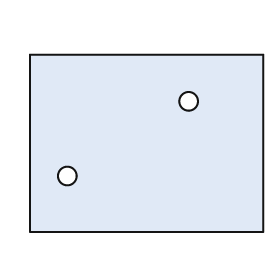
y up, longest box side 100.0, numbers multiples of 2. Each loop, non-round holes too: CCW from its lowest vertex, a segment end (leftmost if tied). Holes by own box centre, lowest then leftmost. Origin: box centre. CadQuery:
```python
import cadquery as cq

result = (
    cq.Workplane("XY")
    .moveTo(-50.0, -38.0)
    .lineTo(50.0, -38.0)
    .lineTo(50.0, 38.0)
    .lineTo(-50.0, 38.0)
    .close()
    .moveTo(-34.0, -14.0)
    .circle(4.0)
    .moveTo(18.0, 18.0)
    .circle(4.0)
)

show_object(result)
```